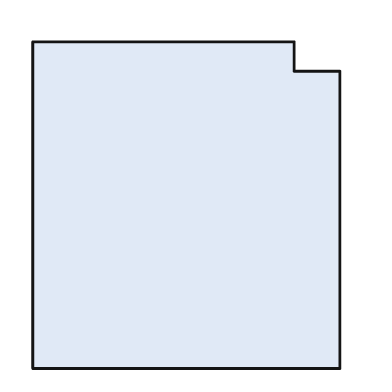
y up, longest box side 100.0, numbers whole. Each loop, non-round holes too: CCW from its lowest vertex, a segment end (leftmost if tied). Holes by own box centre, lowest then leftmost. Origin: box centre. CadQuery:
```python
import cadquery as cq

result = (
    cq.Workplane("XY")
    .moveTo(-47.0, -50.0)
    .lineTo(47.0, -50.0)
    .lineTo(47.0, 41.0)
    .lineTo(33.0, 41.0)
    .lineTo(33.0, 50.0)
    .lineTo(-47.0, 50.0)
    .close()
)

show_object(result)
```